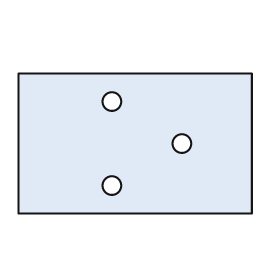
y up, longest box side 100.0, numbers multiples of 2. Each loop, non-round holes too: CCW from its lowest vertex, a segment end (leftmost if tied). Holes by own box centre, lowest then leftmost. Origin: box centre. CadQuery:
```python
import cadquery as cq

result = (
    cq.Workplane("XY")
    .moveTo(-50.0, -30.0)
    .lineTo(50.0, -30.0)
    .lineTo(50.0, 30.0)
    .lineTo(-50.0, 30.0)
    .close()
    .moveTo(-10.0, -18.0)
    .circle(4.0)
    .moveTo(20.0, 0.0)
    .circle(4.0)
    .moveTo(-10.0, 18.0)
    .circle(4.0)
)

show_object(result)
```